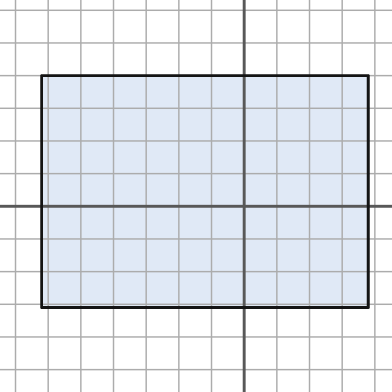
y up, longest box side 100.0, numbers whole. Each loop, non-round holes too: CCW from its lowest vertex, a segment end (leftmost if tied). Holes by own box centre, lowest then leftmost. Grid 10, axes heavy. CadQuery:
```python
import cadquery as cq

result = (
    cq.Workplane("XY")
    .moveTo(-62.0, -31.0)
    .lineTo(38.0, -31.0)
    .lineTo(38.0, 40.0)
    .lineTo(-62.0, 40.0)
    .close()
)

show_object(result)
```